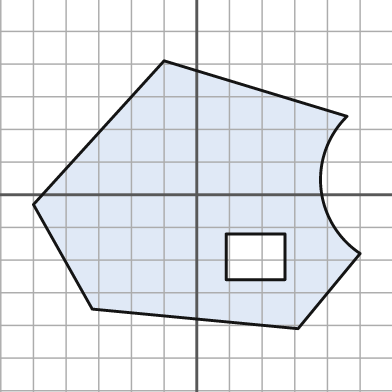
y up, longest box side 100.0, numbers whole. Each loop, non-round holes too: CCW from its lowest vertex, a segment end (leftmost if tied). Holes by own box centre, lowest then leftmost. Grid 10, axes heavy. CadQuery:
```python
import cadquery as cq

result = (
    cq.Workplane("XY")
    .moveTo(31.0, -41.0)
    .lineTo(50.0, -18.0)
    .threePointArc((38.0, 2.0), (46.0, 24.0))
    .lineTo(-10.0, 41.0)
    .lineTo(-50.0, -3.0)
    .lineTo(-32.0, -35.0)
    .close()
    .moveTo(9.0, -26.0)
    .lineTo(27.0, -26.0)
    .lineTo(27.0, -12.0)
    .lineTo(9.0, -12.0)
    .close()
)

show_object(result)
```